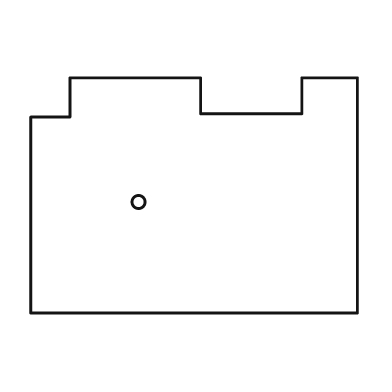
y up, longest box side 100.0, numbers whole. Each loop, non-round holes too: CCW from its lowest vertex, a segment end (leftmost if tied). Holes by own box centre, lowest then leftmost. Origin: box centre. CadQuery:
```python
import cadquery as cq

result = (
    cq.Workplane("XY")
    .moveTo(-50.0, -36.0)
    .lineTo(50.0, -36.0)
    .lineTo(50.0, 36.0)
    .lineTo(33.0, 36.0)
    .lineTo(33.0, 25.0)
    .lineTo(2.0, 25.0)
    .lineTo(2.0, 36.0)
    .lineTo(-38.0, 36.0)
    .lineTo(-38.0, 24.0)
    .lineTo(-50.0, 24.0)
    .close()
    .moveTo(-17.0, -2.0)
    .circle(2.0)
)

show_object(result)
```